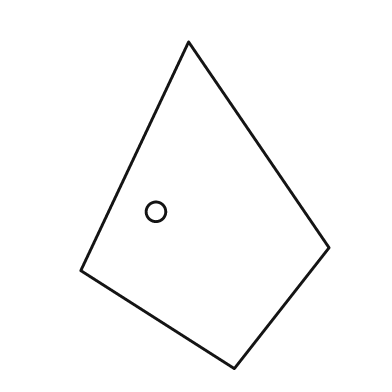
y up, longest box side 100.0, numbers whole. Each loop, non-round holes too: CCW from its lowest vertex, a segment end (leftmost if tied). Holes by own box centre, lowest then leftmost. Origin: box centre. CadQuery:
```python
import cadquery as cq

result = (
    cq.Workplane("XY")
    .moveTo(9.0, -50.0)
    .lineTo(38.0, -13.0)
    .lineTo(-5.0, 50.0)
    .lineTo(-38.0, -20.0)
    .close()
    .moveTo(-15.0, -2.0)
    .circle(3.0)
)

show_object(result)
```